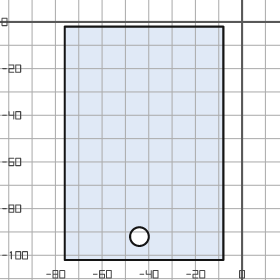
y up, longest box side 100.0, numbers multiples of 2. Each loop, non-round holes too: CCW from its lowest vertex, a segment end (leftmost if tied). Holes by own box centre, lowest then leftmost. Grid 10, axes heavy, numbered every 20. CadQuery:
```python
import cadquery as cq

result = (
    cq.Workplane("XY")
    .moveTo(-76.0, -102.0)
    .lineTo(-8.0, -102.0)
    .lineTo(-8.0, -2.0)
    .lineTo(-76.0, -2.0)
    .close()
    .moveTo(-44.0, -92.0)
    .circle(4.0)
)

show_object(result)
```